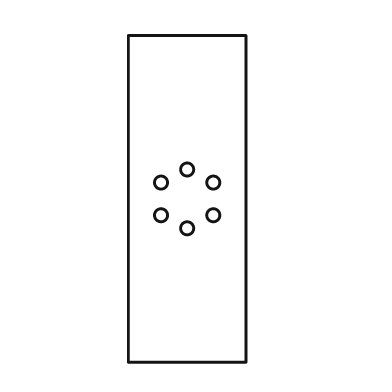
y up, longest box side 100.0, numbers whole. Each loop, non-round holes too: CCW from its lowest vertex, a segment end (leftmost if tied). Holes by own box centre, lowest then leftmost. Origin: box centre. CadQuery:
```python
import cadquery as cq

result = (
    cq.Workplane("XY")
    .moveTo(-18.0, -50.0)
    .lineTo(18.0, -50.0)
    .lineTo(18.0, 50.0)
    .lineTo(-18.0, 50.0)
    .close()
    .moveTo(0.0, -9.0)
    .circle(2.0)
    .moveTo(-8.0, -5.0)
    .circle(2.0)
    .moveTo(8.0, -5.0)
    .circle(2.0)
    .moveTo(-8.0, 5.0)
    .circle(2.0)
    .moveTo(8.0, 5.0)
    .circle(2.0)
    .moveTo(0.0, 9.0)
    .circle(2.0)
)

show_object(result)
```